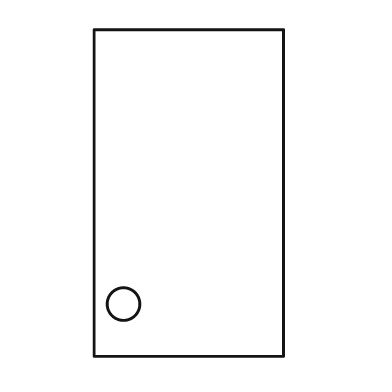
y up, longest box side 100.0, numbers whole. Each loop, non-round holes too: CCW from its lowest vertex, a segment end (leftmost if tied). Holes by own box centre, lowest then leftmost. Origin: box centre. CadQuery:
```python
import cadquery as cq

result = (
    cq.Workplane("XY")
    .moveTo(-29.0, -50.0)
    .lineTo(29.0, -50.0)
    .lineTo(29.0, 50.0)
    .lineTo(-29.0, 50.0)
    .close()
    .moveTo(-20.0, -34.0)
    .circle(5.0)
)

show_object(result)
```